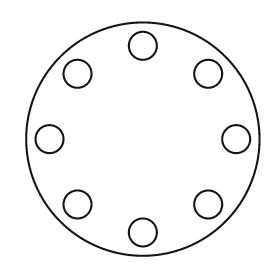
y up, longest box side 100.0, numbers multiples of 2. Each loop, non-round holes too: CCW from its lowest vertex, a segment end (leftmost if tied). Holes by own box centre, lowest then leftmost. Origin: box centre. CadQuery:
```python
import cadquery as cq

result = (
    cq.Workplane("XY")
    .moveTo(0.0, 0.0)
    .circle(50.0)
    .moveTo(0.0, -40.0)
    .circle(6.0)
    .moveTo(-28.0, -28.0)
    .circle(6.0)
    .moveTo(28.0, -28.0)
    .circle(6.0)
    .moveTo(-40.0, 0.0)
    .circle(6.0)
    .moveTo(40.0, 0.0)
    .circle(6.0)
    .moveTo(-28.0, 28.0)
    .circle(6.0)
    .moveTo(28.0, 28.0)
    .circle(6.0)
    .moveTo(0.0, 40.0)
    .circle(6.0)
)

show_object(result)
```